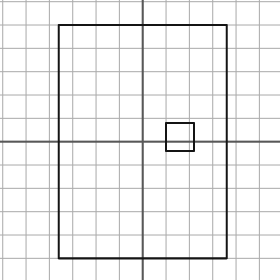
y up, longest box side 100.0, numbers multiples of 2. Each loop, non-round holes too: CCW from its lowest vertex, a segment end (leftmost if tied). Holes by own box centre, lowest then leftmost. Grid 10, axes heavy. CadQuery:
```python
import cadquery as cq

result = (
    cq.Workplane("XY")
    .moveTo(-36.0, -50.0)
    .lineTo(36.0, -50.0)
    .lineTo(36.0, 50.0)
    .lineTo(-36.0, 50.0)
    .close()
    .moveTo(10.0, -4.0)
    .lineTo(22.0, -4.0)
    .lineTo(22.0, 8.0)
    .lineTo(10.0, 8.0)
    .close()
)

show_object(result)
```